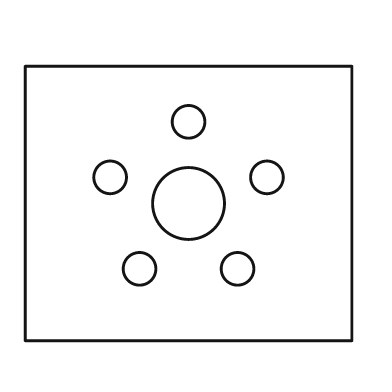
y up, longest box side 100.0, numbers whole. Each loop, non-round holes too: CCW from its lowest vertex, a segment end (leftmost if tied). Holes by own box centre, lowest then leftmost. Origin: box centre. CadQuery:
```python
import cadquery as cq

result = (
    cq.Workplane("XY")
    .moveTo(-50.0, -42.0)
    .lineTo(50.0, -42.0)
    .lineTo(50.0, 42.0)
    .lineTo(-50.0, 42.0)
    .close()
    .moveTo(-15.0, -20.0)
    .circle(5.0)
    .moveTo(15.0, -20.0)
    .circle(5.0)
    .moveTo(0.0, 0.0)
    .circle(11.0)
    .moveTo(-24.0, 8.0)
    .circle(5.0)
    .moveTo(24.0, 8.0)
    .circle(5.0)
    .moveTo(0.0, 25.0)
    .circle(5.0)
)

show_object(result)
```